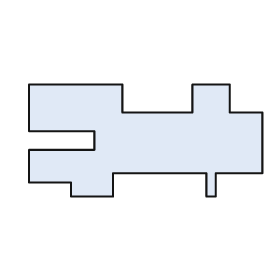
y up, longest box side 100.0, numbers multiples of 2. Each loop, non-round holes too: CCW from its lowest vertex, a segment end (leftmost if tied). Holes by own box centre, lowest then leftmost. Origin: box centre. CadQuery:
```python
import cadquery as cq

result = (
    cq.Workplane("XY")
    .moveTo(-32.0, -24.0)
    .lineTo(-14.0, -24.0)
    .lineTo(-14.0, -14.0)
    .lineTo(26.0, -14.0)
    .lineTo(26.0, -24.0)
    .lineTo(30.0, -24.0)
    .lineTo(30.0, -14.0)
    .lineTo(50.0, -14.0)
    .lineTo(50.0, 12.0)
    .lineTo(36.0, 12.0)
    .lineTo(36.0, 24.0)
    .lineTo(20.0, 24.0)
    .lineTo(20.0, 12.0)
    .lineTo(-10.0, 12.0)
    .lineTo(-10.0, 24.0)
    .lineTo(-50.0, 24.0)
    .lineTo(-50.0, 4.0)
    .lineTo(-22.0, 4.0)
    .lineTo(-22.0, -4.0)
    .lineTo(-50.0, -4.0)
    .lineTo(-50.0, -18.0)
    .lineTo(-32.0, -18.0)
    .close()
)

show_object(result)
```